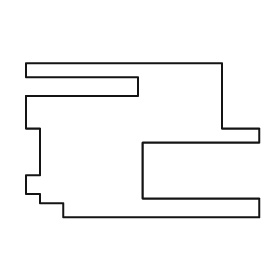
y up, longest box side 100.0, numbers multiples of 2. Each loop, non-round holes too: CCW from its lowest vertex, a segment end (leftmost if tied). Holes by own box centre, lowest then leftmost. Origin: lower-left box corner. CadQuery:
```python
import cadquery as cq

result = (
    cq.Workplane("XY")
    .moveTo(16.0, 0.0)
    .lineTo(100.0, 0.0)
    .lineTo(100.0, 8.0)
    .lineTo(50.0, 8.0)
    .lineTo(50.0, 32.0)
    .lineTo(100.0, 32.0)
    .lineTo(100.0, 38.0)
    .lineTo(84.0, 38.0)
    .lineTo(84.0, 66.0)
    .lineTo(0.0, 66.0)
    .lineTo(0.0, 60.0)
    .lineTo(48.0, 60.0)
    .lineTo(48.0, 52.0)
    .lineTo(0.0, 52.0)
    .lineTo(0.0, 38.0)
    .lineTo(6.0, 38.0)
    .lineTo(6.0, 18.0)
    .lineTo(0.0, 18.0)
    .lineTo(0.0, 10.0)
    .lineTo(6.0, 10.0)
    .lineTo(6.0, 6.0)
    .lineTo(16.0, 6.0)
    .close()
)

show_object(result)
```